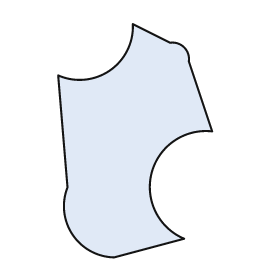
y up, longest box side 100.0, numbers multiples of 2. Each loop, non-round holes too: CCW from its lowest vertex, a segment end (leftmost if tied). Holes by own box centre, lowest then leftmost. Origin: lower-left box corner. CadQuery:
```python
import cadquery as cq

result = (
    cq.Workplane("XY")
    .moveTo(24.0, 0.0)
    .lineTo(54.0, 8.0)
    .threePointArc((40.0, 36.0), (66.0, 54.0))
    .lineTo(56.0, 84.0)
    .threePointArc((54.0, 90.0), (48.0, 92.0))
    .lineTo(32.0, 100.0)
    .threePointArc((22.0, 80.0), (0.0, 78.0))
    .lineTo(4.0, 30.0)
    .threePointArc((6.0, 10.0), (24.0, 0.0))
    .close()
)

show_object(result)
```